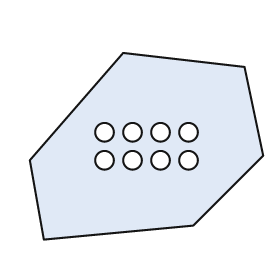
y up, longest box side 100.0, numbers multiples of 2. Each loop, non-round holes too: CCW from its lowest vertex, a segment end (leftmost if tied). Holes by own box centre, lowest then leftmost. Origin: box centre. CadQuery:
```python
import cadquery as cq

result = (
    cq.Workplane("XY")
    .moveTo(-44.0, -40.0)
    .lineTo(20.0, -34.0)
    .lineTo(50.0, -4.0)
    .lineTo(42.0, 34.0)
    .lineTo(-10.0, 40.0)
    .lineTo(-50.0, -6.0)
    .close()
    .moveTo(-18.0, -6.0)
    .circle(4.0)
    .moveTo(-6.0, -6.0)
    .circle(4.0)
    .moveTo(6.0, -6.0)
    .circle(4.0)
    .moveTo(18.0, -6.0)
    .circle(4.0)
    .moveTo(-18.0, 6.0)
    .circle(4.0)
    .moveTo(-6.0, 6.0)
    .circle(4.0)
    .moveTo(6.0, 6.0)
    .circle(4.0)
    .moveTo(18.0, 6.0)
    .circle(4.0)
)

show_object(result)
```